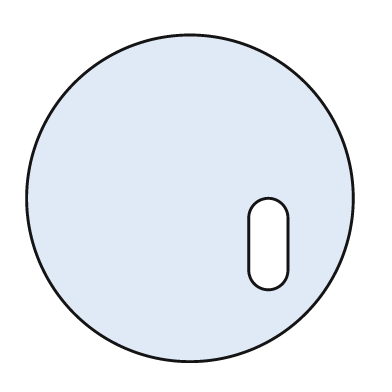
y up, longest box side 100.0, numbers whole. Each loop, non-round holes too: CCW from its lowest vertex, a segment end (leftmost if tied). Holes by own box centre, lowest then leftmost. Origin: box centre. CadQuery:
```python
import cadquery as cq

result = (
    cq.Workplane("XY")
    .moveTo(0.0, 0.0)
    .circle(50.0)
    .moveTo(18.0, -22.0)
    .threePointArc((24.0, -28.0), (30.0, -22.0))
    .lineTo(30.0, -6.0)
    .threePointArc((24.0, 0.0), (18.0, -6.0))
    .close()
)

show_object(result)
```